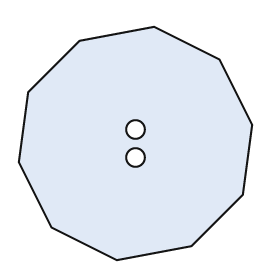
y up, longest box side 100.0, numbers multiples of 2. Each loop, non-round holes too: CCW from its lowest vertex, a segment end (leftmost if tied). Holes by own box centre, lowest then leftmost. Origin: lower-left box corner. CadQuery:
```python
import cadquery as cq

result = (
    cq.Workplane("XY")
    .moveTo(42.0, 0.0)
    .lineTo(74.0, 6.0)
    .lineTo(96.0, 28.0)
    .lineTo(100.0, 58.0)
    .lineTo(86.0, 86.0)
    .lineTo(58.0, 100.0)
    .lineTo(26.0, 94.0)
    .lineTo(4.0, 72.0)
    .lineTo(0.0, 42.0)
    .lineTo(14.0, 14.0)
    .close()
    .moveTo(50.0, 44.0)
    .circle(4.0)
    .moveTo(50.0, 56.0)
    .circle(4.0)
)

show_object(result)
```